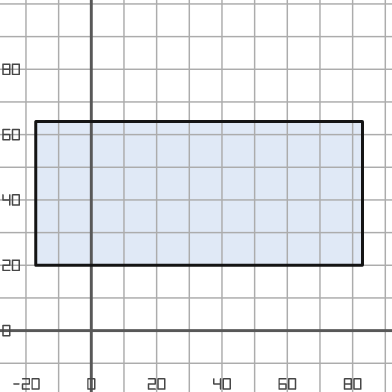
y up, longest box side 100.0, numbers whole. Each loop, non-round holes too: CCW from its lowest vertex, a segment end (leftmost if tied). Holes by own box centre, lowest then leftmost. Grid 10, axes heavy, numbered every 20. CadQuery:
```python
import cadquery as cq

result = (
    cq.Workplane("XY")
    .moveTo(-17.0, 20.0)
    .lineTo(83.0, 20.0)
    .lineTo(83.0, 64.0)
    .lineTo(-17.0, 64.0)
    .close()
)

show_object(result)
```